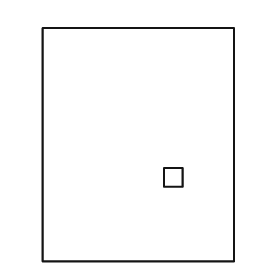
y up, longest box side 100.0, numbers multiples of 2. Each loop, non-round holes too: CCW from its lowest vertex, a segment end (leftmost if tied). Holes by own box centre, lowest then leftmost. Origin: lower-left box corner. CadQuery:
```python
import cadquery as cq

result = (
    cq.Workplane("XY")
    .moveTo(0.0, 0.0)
    .lineTo(82.0, 0.0)
    .lineTo(82.0, 100.0)
    .lineTo(0.0, 100.0)
    .close()
    .moveTo(52.0, 32.0)
    .lineTo(60.0, 32.0)
    .lineTo(60.0, 40.0)
    .lineTo(52.0, 40.0)
    .close()
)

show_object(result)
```